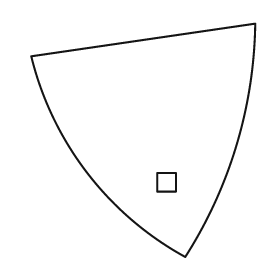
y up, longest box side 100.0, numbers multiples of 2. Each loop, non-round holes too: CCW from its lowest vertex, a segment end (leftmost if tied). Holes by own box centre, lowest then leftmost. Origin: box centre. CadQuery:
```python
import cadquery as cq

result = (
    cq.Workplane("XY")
    .moveTo(18.0, -50.0)
    .threePointArc((40.0, -2.0), (48.0, 50.0))
    .lineTo(-48.0, 36.0)
    .threePointArc((-24.0, -14.0), (18.0, -50.0))
    .close()
    .moveTo(6.0, -22.0)
    .lineTo(14.0, -22.0)
    .lineTo(14.0, -14.0)
    .lineTo(6.0, -14.0)
    .close()
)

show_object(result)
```